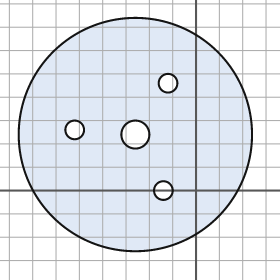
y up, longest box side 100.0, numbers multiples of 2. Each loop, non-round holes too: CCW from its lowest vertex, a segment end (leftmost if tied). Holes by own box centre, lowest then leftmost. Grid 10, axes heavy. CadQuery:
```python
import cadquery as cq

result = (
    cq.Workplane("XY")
    .moveTo(-26.0, 24.0)
    .circle(50.0)
    .moveTo(-14.0, 0.0)
    .circle(4.0)
    .moveTo(-26.0, 24.0)
    .circle(6.0)
    .moveTo(-52.0, 26.0)
    .circle(4.0)
    .moveTo(-12.0, 46.0)
    .circle(4.0)
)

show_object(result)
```